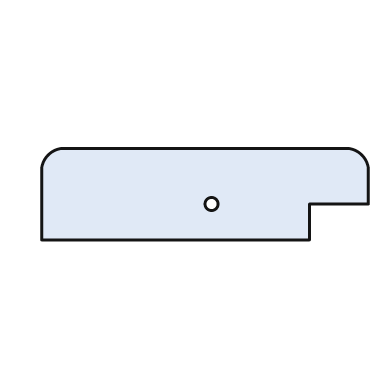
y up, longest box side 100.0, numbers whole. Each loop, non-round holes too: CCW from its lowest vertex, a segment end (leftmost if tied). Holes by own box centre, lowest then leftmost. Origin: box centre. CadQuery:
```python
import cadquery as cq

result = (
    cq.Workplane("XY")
    .moveTo(-50.0, -14.0)
    .lineTo(32.0, -14.0)
    .lineTo(32.0, -3.0)
    .lineTo(50.0, -3.0)
    .lineTo(50.0, 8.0)
    .threePointArc((48.0, 12.0), (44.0, 14.0))
    .lineTo(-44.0, 14.0)
    .threePointArc((-48.0, 12.0), (-50.0, 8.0))
    .close()
    .moveTo(2.0, -3.0)
    .circle(2.0)
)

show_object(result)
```